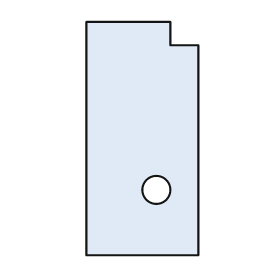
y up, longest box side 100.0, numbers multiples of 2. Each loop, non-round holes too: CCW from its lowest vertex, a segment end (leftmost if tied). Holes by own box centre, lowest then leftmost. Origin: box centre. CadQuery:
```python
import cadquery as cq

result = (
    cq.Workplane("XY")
    .moveTo(-24.0, -50.0)
    .lineTo(24.0, -50.0)
    .lineTo(24.0, 40.0)
    .lineTo(12.0, 40.0)
    .lineTo(12.0, 50.0)
    .lineTo(-24.0, 50.0)
    .close()
    .moveTo(6.0, -22.0)
    .circle(6.0)
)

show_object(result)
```